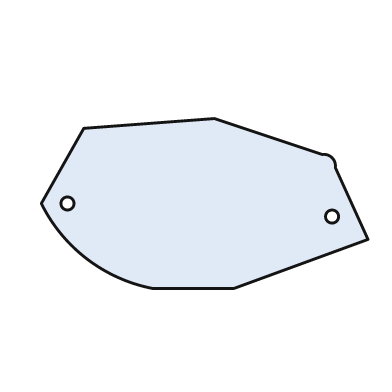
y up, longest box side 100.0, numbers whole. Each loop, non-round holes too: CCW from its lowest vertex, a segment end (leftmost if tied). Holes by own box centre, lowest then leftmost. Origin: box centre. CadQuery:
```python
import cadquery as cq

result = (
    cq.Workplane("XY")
    .moveTo(-16.0, -26.0)
    .lineTo(9.0, -26.0)
    .lineTo(50.0, -11.0)
    .lineTo(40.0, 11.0)
    .threePointArc((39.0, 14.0), (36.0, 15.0))
    .lineTo(3.0, 26.0)
    .lineTo(-37.0, 23.0)
    .lineTo(-50.0, 0.0)
    .threePointArc((-36.0, -17.0), (-16.0, -26.0))
    .close()
    .moveTo(39.0, -4.0)
    .circle(2.0)
    .moveTo(-42.0, 0.0)
    .circle(2.0)
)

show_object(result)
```